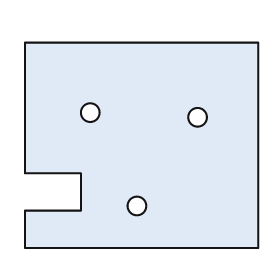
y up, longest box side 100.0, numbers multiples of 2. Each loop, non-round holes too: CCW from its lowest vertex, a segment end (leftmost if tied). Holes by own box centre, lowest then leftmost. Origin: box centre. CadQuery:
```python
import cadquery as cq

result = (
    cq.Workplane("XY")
    .moveTo(-50.0, -44.0)
    .lineTo(50.0, -44.0)
    .lineTo(50.0, 44.0)
    .lineTo(-50.0, 44.0)
    .lineTo(-50.0, -12.0)
    .lineTo(-26.0, -12.0)
    .lineTo(-26.0, -28.0)
    .lineTo(-50.0, -28.0)
    .close()
    .moveTo(-2.0, -26.0)
    .circle(4.0)
    .moveTo(24.0, 12.0)
    .circle(4.0)
    .moveTo(-22.0, 14.0)
    .circle(4.0)
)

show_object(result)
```